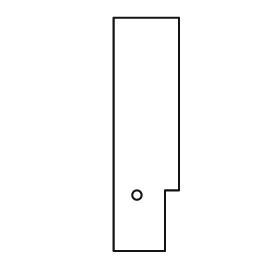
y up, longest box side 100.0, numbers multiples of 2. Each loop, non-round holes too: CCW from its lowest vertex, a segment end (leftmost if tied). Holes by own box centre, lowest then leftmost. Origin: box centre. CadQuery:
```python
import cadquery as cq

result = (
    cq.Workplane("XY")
    .moveTo(-14.0, -50.0)
    .lineTo(8.0, -50.0)
    .lineTo(8.0, -24.0)
    .lineTo(14.0, -24.0)
    .lineTo(14.0, 50.0)
    .lineTo(-14.0, 50.0)
    .close()
    .moveTo(-4.0, -26.0)
    .circle(2.0)
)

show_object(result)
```